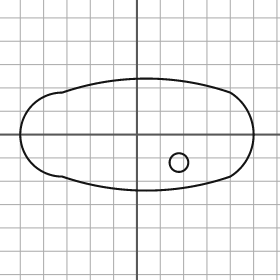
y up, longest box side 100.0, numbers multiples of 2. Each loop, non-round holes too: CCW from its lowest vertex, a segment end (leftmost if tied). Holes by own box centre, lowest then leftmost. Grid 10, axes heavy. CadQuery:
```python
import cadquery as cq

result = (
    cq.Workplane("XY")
    .moveTo(-32.0, -18.0)
    .threePointArc((4.0, -24.0), (40.0, -18.0))
    .threePointArc((50.0, 0.0), (40.0, 18.0))
    .threePointArc((4.0, 24.0), (-32.0, 18.0))
    .threePointArc((-50.0, 0.0), (-32.0, -18.0))
    .close()
    .moveTo(18.0, -12.0)
    .circle(4.0)
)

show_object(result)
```